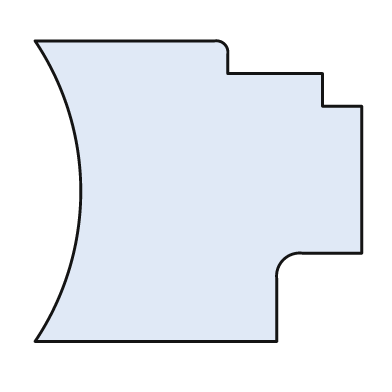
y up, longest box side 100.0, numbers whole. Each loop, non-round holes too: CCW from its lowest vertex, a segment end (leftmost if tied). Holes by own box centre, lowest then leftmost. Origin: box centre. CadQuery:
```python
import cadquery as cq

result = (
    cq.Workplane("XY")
    .moveTo(-50.0, -46.0)
    .lineTo(24.0, -46.0)
    .lineTo(24.0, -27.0)
    .threePointArc((26.0, -21.0), (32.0, -19.0))
    .lineTo(50.0, -19.0)
    .lineTo(50.0, 26.0)
    .lineTo(38.0, 26.0)
    .lineTo(38.0, 36.0)
    .lineTo(9.0, 36.0)
    .lineTo(9.0, 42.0)
    .threePointArc((8.0, 45.0), (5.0, 46.0))
    .lineTo(-50.0, 46.0)
    .threePointArc((-36.0, 0.0), (-50.0, -46.0))
    .close()
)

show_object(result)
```